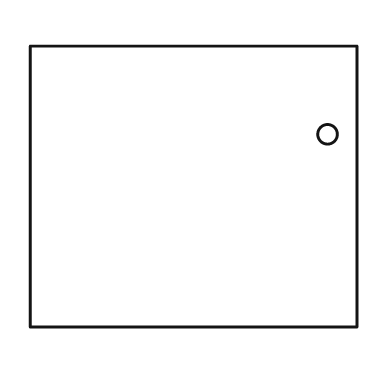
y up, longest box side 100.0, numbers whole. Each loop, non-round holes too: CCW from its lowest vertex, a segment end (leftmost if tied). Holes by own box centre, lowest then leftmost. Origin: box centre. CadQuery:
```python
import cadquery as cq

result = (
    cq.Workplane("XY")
    .moveTo(-50.0, -43.0)
    .lineTo(50.0, -43.0)
    .lineTo(50.0, 43.0)
    .lineTo(-50.0, 43.0)
    .close()
    .moveTo(41.0, 16.0)
    .circle(3.0)
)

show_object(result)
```